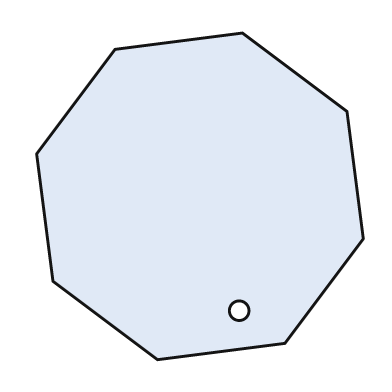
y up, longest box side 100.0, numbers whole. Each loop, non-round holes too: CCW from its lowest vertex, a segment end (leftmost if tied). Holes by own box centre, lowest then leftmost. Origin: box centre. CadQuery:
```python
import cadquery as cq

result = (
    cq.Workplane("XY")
    .moveTo(-13.0, -50.0)
    .lineTo(26.0, -45.0)
    .lineTo(50.0, -13.0)
    .lineTo(45.0, 26.0)
    .lineTo(13.0, 50.0)
    .lineTo(-26.0, 45.0)
    .lineTo(-50.0, 13.0)
    .lineTo(-45.0, -26.0)
    .close()
    .moveTo(12.0, -35.0)
    .circle(3.0)
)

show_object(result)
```